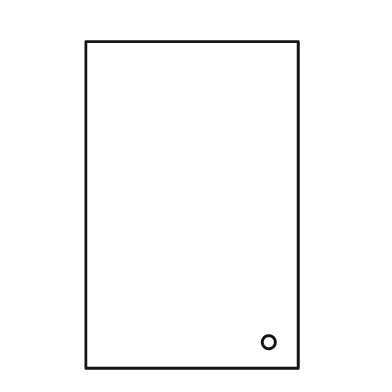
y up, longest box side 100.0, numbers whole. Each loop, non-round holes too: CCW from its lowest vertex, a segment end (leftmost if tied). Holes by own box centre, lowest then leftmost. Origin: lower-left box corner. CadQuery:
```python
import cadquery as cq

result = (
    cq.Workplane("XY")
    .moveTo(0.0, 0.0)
    .lineTo(65.0, 0.0)
    .lineTo(65.0, 100.0)
    .lineTo(0.0, 100.0)
    .close()
    .moveTo(56.0, 8.0)
    .circle(2.0)
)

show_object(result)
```